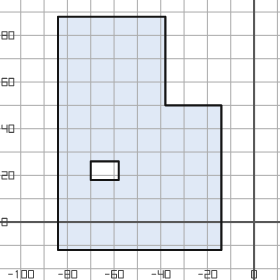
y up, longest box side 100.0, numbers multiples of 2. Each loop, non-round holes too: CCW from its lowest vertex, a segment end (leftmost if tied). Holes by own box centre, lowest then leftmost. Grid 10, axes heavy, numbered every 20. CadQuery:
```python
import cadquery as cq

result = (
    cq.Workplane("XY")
    .moveTo(-84.0, -12.0)
    .lineTo(-14.0, -12.0)
    .lineTo(-14.0, 50.0)
    .lineTo(-38.0, 50.0)
    .lineTo(-38.0, 88.0)
    .lineTo(-84.0, 88.0)
    .close()
    .moveTo(-70.0, 18.0)
    .lineTo(-58.0, 18.0)
    .lineTo(-58.0, 26.0)
    .lineTo(-70.0, 26.0)
    .close()
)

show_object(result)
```